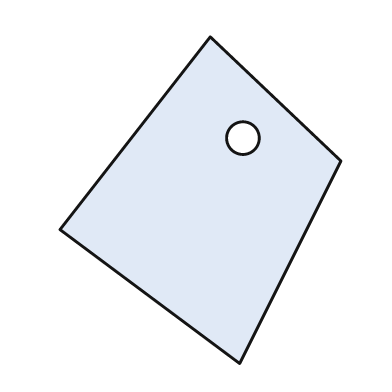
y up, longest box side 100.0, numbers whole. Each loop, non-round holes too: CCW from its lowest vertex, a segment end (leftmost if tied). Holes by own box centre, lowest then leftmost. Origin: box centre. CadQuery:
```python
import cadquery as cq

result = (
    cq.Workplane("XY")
    .moveTo(12.0, -50.0)
    .lineTo(43.0, 12.0)
    .lineTo(3.0, 50.0)
    .lineTo(-43.0, -9.0)
    .close()
    .moveTo(13.0, 19.0)
    .circle(5.0)
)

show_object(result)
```